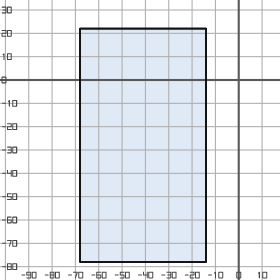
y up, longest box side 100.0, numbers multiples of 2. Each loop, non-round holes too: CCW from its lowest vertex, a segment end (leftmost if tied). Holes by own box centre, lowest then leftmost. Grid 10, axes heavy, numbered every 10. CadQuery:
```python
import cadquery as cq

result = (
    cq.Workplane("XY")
    .moveTo(-68.0, -78.0)
    .lineTo(-14.0, -78.0)
    .lineTo(-14.0, 22.0)
    .lineTo(-68.0, 22.0)
    .close()
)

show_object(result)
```